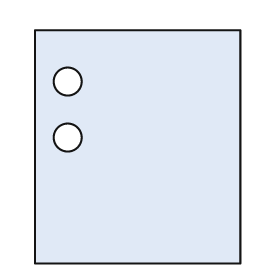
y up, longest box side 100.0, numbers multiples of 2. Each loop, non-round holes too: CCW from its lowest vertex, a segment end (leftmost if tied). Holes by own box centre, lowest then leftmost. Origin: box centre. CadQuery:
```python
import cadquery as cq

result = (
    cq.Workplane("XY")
    .moveTo(-44.0, -50.0)
    .lineTo(44.0, -50.0)
    .lineTo(44.0, 50.0)
    .lineTo(-44.0, 50.0)
    .close()
    .moveTo(-30.0, 4.0)
    .circle(6.0)
    .moveTo(-30.0, 28.0)
    .circle(6.0)
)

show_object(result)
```